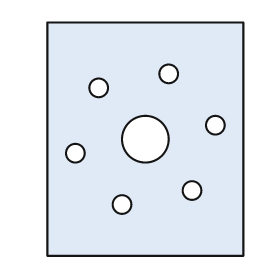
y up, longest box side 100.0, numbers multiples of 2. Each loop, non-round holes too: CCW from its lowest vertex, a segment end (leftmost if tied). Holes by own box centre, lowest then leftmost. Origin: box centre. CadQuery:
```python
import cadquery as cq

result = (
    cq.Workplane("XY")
    .moveTo(-42.0, -50.0)
    .lineTo(42.0, -50.0)
    .lineTo(42.0, 50.0)
    .lineTo(-42.0, 50.0)
    .close()
    .moveTo(-10.0, -28.0)
    .circle(4.0)
    .moveTo(20.0, -22.0)
    .circle(4.0)
    .moveTo(-30.0, -6.0)
    .circle(4.0)
    .moveTo(0.0, 0.0)
    .circle(10.0)
    .moveTo(30.0, 6.0)
    .circle(4.0)
    .moveTo(-20.0, 22.0)
    .circle(4.0)
    .moveTo(10.0, 28.0)
    .circle(4.0)
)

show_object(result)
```